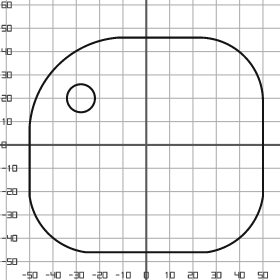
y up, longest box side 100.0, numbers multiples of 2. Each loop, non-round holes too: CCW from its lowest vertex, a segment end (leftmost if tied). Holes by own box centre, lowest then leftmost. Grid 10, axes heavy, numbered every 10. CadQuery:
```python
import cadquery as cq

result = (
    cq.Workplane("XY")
    .moveTo(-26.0, -46.0)
    .lineTo(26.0, -46.0)
    .threePointArc((42.0, -38.0), (50.0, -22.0))
    .lineTo(50.0, 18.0)
    .threePointArc((42.0, 38.0), (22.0, 46.0))
    .lineTo(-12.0, 46.0)
    .threePointArc((-38.0, 34.0), (-50.0, 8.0))
    .lineTo(-50.0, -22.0)
    .threePointArc((-42.0, -38.0), (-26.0, -46.0))
    .close()
    .moveTo(-28.0, 20.0)
    .circle(6.0)
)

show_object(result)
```